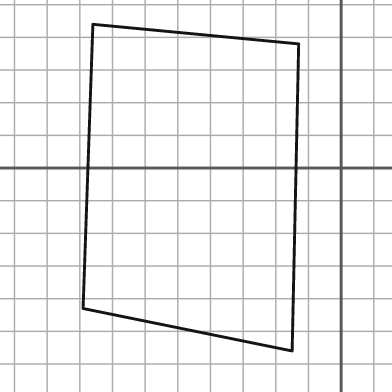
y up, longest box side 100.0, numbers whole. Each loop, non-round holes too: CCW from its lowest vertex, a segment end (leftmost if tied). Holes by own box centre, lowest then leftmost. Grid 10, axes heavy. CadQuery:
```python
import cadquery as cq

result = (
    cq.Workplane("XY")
    .moveTo(-15.0, -56.0)
    .lineTo(-13.0, 38.0)
    .lineTo(-76.0, 44.0)
    .lineTo(-79.0, -43.0)
    .close()
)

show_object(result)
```